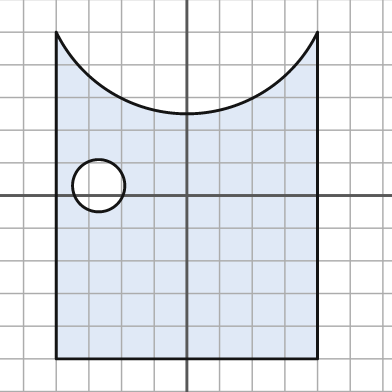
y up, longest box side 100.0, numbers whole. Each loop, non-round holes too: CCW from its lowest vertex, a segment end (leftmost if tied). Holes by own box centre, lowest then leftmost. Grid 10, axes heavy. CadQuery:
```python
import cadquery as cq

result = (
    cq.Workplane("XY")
    .moveTo(-40.0, -50.0)
    .lineTo(40.0, -50.0)
    .lineTo(40.0, 50.0)
    .threePointArc((0.0, 25.0), (-40.0, 50.0))
    .close()
    .moveTo(-27.0, 3.0)
    .circle(8.0)
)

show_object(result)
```